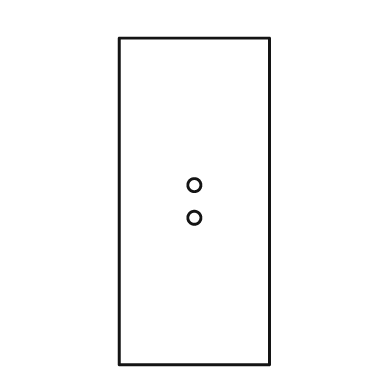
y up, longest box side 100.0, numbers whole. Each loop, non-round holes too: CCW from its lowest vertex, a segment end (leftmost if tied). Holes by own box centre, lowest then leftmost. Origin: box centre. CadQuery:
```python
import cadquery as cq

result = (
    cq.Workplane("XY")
    .moveTo(-23.0, -50.0)
    .lineTo(23.0, -50.0)
    .lineTo(23.0, 50.0)
    .lineTo(-23.0, 50.0)
    .close()
    .moveTo(0.0, -5.0)
    .circle(2.0)
    .moveTo(0.0, 5.0)
    .circle(2.0)
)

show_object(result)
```